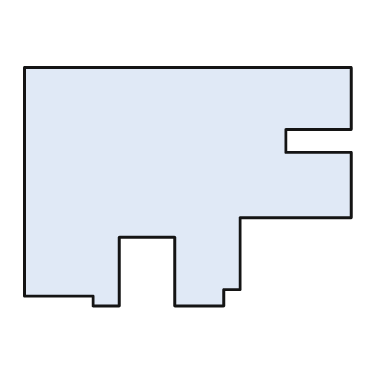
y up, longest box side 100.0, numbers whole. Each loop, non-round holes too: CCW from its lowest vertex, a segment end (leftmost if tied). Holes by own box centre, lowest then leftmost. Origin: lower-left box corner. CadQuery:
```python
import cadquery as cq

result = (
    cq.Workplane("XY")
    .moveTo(21.0, 0.0)
    .lineTo(29.0, 0.0)
    .lineTo(29.0, 21.0)
    .lineTo(46.0, 21.0)
    .lineTo(46.0, 0.0)
    .lineTo(61.0, 0.0)
    .lineTo(61.0, 5.0)
    .lineTo(66.0, 5.0)
    .lineTo(66.0, 27.0)
    .lineTo(100.0, 27.0)
    .lineTo(100.0, 47.0)
    .lineTo(80.0, 47.0)
    .lineTo(80.0, 54.0)
    .lineTo(100.0, 54.0)
    .lineTo(100.0, 73.0)
    .lineTo(0.0, 73.0)
    .lineTo(0.0, 3.0)
    .lineTo(21.0, 3.0)
    .close()
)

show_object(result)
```